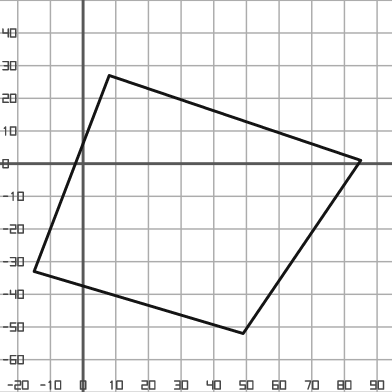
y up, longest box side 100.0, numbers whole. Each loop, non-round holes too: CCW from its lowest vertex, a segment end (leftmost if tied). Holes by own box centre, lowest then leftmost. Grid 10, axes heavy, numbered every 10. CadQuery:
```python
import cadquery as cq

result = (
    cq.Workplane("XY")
    .moveTo(49.0, -52.0)
    .lineTo(85.0, 1.0)
    .lineTo(8.0, 27.0)
    .lineTo(-15.0, -33.0)
    .close()
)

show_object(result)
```